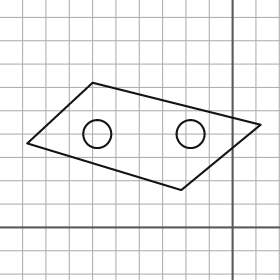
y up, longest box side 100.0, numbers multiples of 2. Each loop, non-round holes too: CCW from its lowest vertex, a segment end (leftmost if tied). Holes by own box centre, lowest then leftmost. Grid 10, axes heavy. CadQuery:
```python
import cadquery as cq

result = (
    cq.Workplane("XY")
    .moveTo(-22.0, 16.0)
    .lineTo(12.0, 44.0)
    .lineTo(-60.0, 62.0)
    .lineTo(-88.0, 36.0)
    .close()
    .moveTo(-58.0, 40.0)
    .circle(6.0)
    .moveTo(-18.0, 40.0)
    .circle(6.0)
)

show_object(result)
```